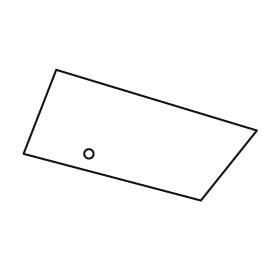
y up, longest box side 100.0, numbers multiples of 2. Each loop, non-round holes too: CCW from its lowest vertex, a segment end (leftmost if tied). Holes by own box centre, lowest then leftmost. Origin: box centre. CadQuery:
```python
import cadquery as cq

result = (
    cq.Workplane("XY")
    .moveTo(26.0, -28.0)
    .lineTo(50.0, 2.0)
    .lineTo(-36.0, 28.0)
    .lineTo(-50.0, -8.0)
    .close()
    .moveTo(-22.0, -8.0)
    .circle(2.0)
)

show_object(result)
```